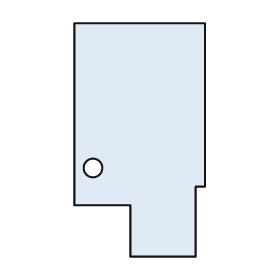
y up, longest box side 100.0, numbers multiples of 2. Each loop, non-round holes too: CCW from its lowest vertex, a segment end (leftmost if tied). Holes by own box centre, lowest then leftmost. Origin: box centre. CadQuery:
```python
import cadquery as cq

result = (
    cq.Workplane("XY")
    .moveTo(-4.0, -50.0)
    .lineTo(24.0, -50.0)
    .lineTo(24.0, -20.0)
    .lineTo(28.0, -20.0)
    .lineTo(28.0, 50.0)
    .lineTo(-28.0, 50.0)
    .lineTo(-28.0, -28.0)
    .lineTo(-4.0, -28.0)
    .close()
    .moveTo(-20.0, -12.0)
    .circle(4.0)
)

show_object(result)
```